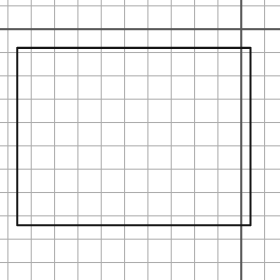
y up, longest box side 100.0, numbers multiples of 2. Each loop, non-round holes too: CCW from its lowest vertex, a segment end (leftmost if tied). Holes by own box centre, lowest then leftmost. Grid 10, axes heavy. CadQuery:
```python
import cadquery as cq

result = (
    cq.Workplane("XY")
    .moveTo(-96.0, -84.0)
    .lineTo(4.0, -84.0)
    .lineTo(4.0, -8.0)
    .lineTo(-96.0, -8.0)
    .close()
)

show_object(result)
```